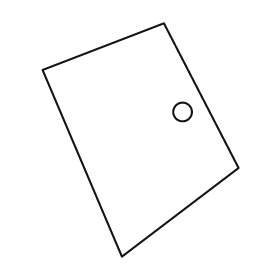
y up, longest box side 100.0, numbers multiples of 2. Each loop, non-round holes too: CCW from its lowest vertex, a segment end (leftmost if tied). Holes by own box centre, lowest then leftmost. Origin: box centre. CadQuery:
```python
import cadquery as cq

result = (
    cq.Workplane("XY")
    .moveTo(-8.0, -50.0)
    .lineTo(42.0, -12.0)
    .lineTo(10.0, 50.0)
    .lineTo(-42.0, 30.0)
    .close()
    .moveTo(18.0, 12.0)
    .circle(4.0)
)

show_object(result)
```